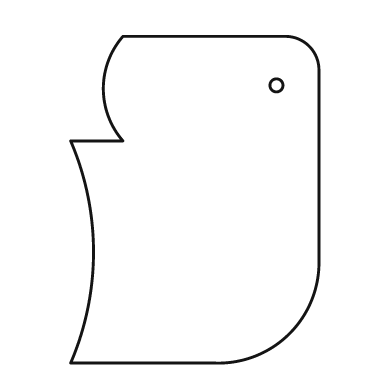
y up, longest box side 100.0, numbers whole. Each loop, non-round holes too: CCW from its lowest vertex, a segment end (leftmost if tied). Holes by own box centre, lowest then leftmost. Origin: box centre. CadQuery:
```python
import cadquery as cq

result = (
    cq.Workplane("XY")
    .moveTo(-38.0, -50.0)
    .lineTo(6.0, -50.0)
    .threePointArc((29.0, -41.0), (38.0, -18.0))
    .lineTo(38.0, 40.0)
    .threePointArc((35.0, 47.0), (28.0, 50.0))
    .lineTo(-22.0, 50.0)
    .threePointArc((-28.0, 34.0), (-22.0, 18.0))
    .lineTo(-38.0, 18.0)
    .threePointArc((-31.0, -16.0), (-38.0, -50.0))
    .close()
    .moveTo(25.0, 35.0)
    .circle(2.0)
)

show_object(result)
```